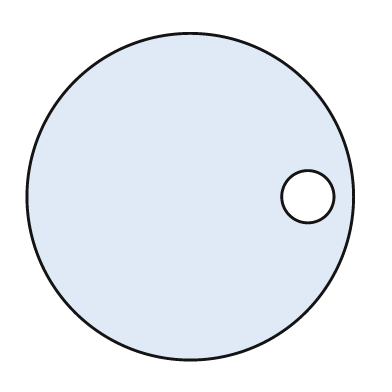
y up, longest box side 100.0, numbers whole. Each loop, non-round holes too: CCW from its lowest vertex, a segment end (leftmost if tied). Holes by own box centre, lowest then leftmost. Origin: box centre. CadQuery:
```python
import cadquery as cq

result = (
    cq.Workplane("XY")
    .moveTo(0.0, 0.0)
    .circle(50.0)
    .moveTo(36.0, 0.0)
    .circle(8.0)
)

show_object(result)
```